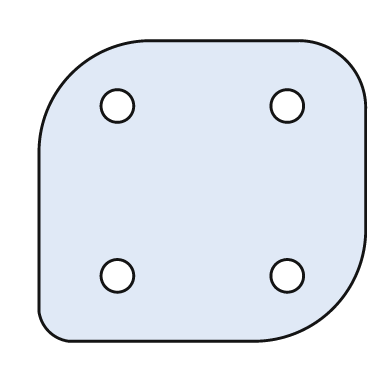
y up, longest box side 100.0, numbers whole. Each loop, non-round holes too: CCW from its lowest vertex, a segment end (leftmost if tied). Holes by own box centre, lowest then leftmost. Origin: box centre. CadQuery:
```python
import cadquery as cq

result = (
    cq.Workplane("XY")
    .moveTo(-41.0, -46.0)
    .lineTo(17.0, -46.0)
    .threePointArc((40.0, -36.0), (50.0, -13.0))
    .lineTo(50.0, 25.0)
    .threePointArc((44.0, 40.0), (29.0, 46.0))
    .lineTo(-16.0, 46.0)
    .threePointArc((-40.0, 36.0), (-50.0, 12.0))
    .lineTo(-50.0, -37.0)
    .threePointArc((-47.0, -43.0), (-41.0, -46.0))
    .close()
    .moveTo(-26.0, -26.0)
    .circle(5.0)
    .moveTo(26.0, -26.0)
    .circle(5.0)
    .moveTo(-26.0, 26.0)
    .circle(5.0)
    .moveTo(26.0, 26.0)
    .circle(5.0)
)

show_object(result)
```